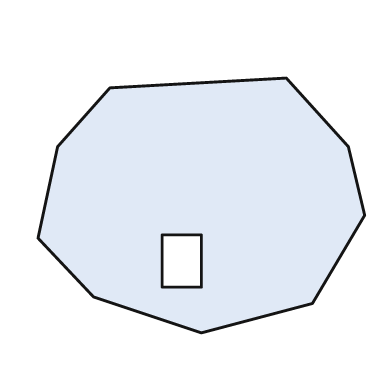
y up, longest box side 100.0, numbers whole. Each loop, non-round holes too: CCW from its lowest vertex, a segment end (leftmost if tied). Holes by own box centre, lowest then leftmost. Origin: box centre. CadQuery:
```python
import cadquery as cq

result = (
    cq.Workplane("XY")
    .moveTo(0.0, -39.0)
    .lineTo(34.0, -30.0)
    .lineTo(50.0, -3.0)
    .lineTo(45.0, 18.0)
    .lineTo(26.0, 39.0)
    .lineTo(-28.0, 36.0)
    .lineTo(-44.0, 18.0)
    .lineTo(-50.0, -10.0)
    .lineTo(-33.0, -28.0)
    .close()
    .moveTo(-12.0, -25.0)
    .lineTo(0.0, -25.0)
    .lineTo(0.0, -9.0)
    .lineTo(-12.0, -9.0)
    .close()
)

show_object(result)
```